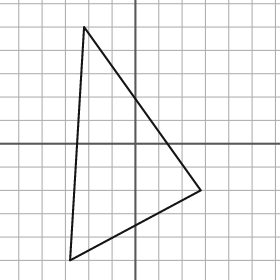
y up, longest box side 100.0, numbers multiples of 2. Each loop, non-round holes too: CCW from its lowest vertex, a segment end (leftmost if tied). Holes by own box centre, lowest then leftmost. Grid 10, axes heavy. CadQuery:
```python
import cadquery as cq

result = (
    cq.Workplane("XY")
    .moveTo(-28.0, -50.0)
    .lineTo(28.0, -20.0)
    .lineTo(-22.0, 50.0)
    .close()
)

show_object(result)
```